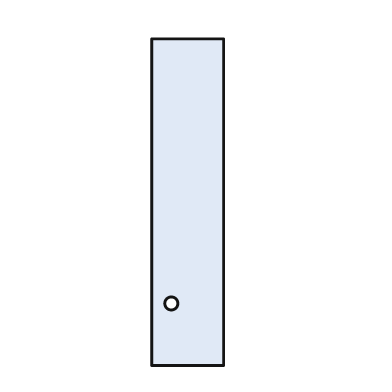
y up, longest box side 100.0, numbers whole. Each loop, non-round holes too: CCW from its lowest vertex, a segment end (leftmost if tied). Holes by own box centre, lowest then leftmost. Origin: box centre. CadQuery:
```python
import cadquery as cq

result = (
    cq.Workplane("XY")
    .moveTo(-11.0, -50.0)
    .lineTo(11.0, -50.0)
    .lineTo(11.0, 50.0)
    .lineTo(-11.0, 50.0)
    .close()
    .moveTo(-5.0, -31.0)
    .circle(2.0)
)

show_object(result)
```